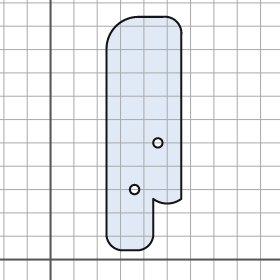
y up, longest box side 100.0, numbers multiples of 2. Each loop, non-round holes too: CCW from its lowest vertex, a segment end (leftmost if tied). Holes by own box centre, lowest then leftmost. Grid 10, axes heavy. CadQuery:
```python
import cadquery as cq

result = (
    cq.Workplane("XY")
    .moveTo(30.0, 4.0)
    .lineTo(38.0, 4.0)
    .threePointArc((42.0, 6.0), (44.0, 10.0))
    .lineTo(44.0, 26.0)
    .threePointArc((50.0, 24.0), (56.0, 26.0))
    .lineTo(56.0, 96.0)
    .threePointArc((54.0, 102.0), (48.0, 104.0))
    .lineTo(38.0, 104.0)
    .threePointArc((28.0, 100.0), (24.0, 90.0))
    .lineTo(24.0, 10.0)
    .threePointArc((26.0, 6.0), (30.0, 4.0))
    .close()
    .moveTo(36.0, 30.0)
    .circle(2.0)
    .moveTo(46.0, 50.0)
    .circle(2.0)
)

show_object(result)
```